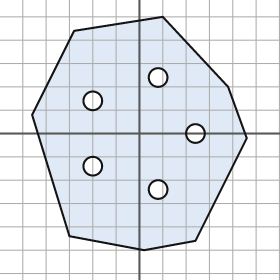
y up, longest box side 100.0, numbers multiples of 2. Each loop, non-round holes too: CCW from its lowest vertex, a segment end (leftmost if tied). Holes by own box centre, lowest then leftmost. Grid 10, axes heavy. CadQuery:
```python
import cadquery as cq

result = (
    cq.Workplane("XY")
    .moveTo(2.0, -50.0)
    .lineTo(24.0, -46.0)
    .lineTo(46.0, -2.0)
    .lineTo(38.0, 20.0)
    .lineTo(10.0, 50.0)
    .lineTo(-28.0, 44.0)
    .lineTo(-46.0, 8.0)
    .lineTo(-30.0, -44.0)
    .close()
    .moveTo(8.0, -24.0)
    .circle(4.0)
    .moveTo(-20.0, -14.0)
    .circle(4.0)
    .moveTo(24.0, 0.0)
    .circle(4.0)
    .moveTo(-20.0, 14.0)
    .circle(4.0)
    .moveTo(8.0, 24.0)
    .circle(4.0)
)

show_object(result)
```